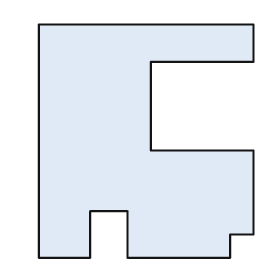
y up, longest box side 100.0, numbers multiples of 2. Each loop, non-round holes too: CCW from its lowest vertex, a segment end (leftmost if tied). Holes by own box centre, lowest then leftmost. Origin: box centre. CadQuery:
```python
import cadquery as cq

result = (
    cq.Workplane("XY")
    .moveTo(-46.0, -50.0)
    .lineTo(-24.0, -50.0)
    .lineTo(-24.0, -30.0)
    .lineTo(-8.0, -30.0)
    .lineTo(-8.0, -50.0)
    .lineTo(36.0, -50.0)
    .lineTo(36.0, -40.0)
    .lineTo(46.0, -40.0)
    .lineTo(46.0, -4.0)
    .lineTo(2.0, -4.0)
    .lineTo(2.0, 34.0)
    .lineTo(46.0, 34.0)
    .lineTo(46.0, 50.0)
    .lineTo(-46.0, 50.0)
    .close()
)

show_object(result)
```